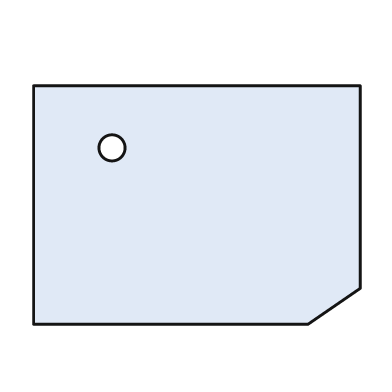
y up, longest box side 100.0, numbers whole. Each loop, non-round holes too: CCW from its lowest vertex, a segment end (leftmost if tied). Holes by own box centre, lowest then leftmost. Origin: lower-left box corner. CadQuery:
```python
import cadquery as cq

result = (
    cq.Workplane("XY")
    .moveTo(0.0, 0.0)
    .lineTo(84.0, 0.0)
    .lineTo(100.0, 11.0)
    .lineTo(100.0, 73.0)
    .lineTo(0.0, 73.0)
    .close()
    .moveTo(24.0, 54.0)
    .circle(4.0)
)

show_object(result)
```